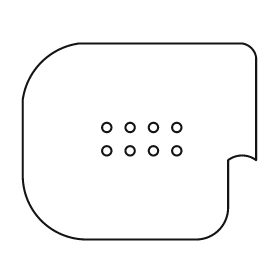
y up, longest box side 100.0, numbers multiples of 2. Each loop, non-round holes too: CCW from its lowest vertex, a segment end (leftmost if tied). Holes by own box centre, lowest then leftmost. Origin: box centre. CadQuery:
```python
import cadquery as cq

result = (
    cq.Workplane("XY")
    .moveTo(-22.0, -42.0)
    .lineTo(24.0, -42.0)
    .threePointArc((34.0, -38.0), (38.0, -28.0))
    .lineTo(38.0, -8.0)
    .threePointArc((44.0, -6.0), (50.0, -8.0))
    .lineTo(50.0, 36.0)
    .threePointArc((48.0, 40.0), (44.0, 42.0))
    .lineTo(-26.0, 42.0)
    .threePointArc((-42.0, 34.0), (-50.0, 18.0))
    .lineTo(-50.0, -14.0)
    .threePointArc((-42.0, -34.0), (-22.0, -42.0))
    .close()
    .moveTo(-14.0, -4.0)
    .circle(2.0)
    .moveTo(-4.0, -4.0)
    .circle(2.0)
    .moveTo(6.0, -4.0)
    .circle(2.0)
    .moveTo(16.0, -4.0)
    .circle(2.0)
    .moveTo(-14.0, 6.0)
    .circle(2.0)
    .moveTo(-4.0, 6.0)
    .circle(2.0)
    .moveTo(6.0, 6.0)
    .circle(2.0)
    .moveTo(16.0, 6.0)
    .circle(2.0)
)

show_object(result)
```